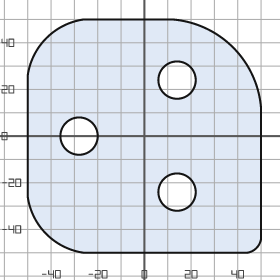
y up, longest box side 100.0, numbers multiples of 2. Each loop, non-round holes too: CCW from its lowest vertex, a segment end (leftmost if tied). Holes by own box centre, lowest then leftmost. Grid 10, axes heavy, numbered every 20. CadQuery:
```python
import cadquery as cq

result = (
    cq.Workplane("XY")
    .moveTo(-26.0, -50.0)
    .lineTo(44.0, -50.0)
    .threePointArc((48.0, -48.0), (50.0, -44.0))
    .lineTo(50.0, 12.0)
    .threePointArc((38.0, 38.0), (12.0, 50.0))
    .lineTo(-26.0, 50.0)
    .threePointArc((-42.0, 42.0), (-50.0, 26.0))
    .lineTo(-50.0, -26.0)
    .threePointArc((-42.0, -42.0), (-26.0, -50.0))
    .close()
    .moveTo(14.0, -24.0)
    .circle(8.0)
    .moveTo(-28.0, 0.0)
    .circle(8.0)
    .moveTo(14.0, 24.0)
    .circle(8.0)
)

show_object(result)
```